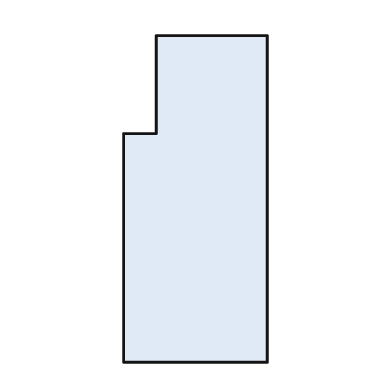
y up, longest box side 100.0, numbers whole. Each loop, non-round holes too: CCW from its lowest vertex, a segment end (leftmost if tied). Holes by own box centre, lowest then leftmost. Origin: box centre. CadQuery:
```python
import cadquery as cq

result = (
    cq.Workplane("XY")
    .moveTo(-22.0, -50.0)
    .lineTo(22.0, -50.0)
    .lineTo(22.0, 50.0)
    .lineTo(-12.0, 50.0)
    .lineTo(-12.0, 20.0)
    .lineTo(-22.0, 20.0)
    .close()
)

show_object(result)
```